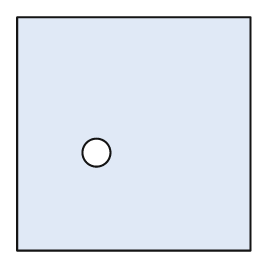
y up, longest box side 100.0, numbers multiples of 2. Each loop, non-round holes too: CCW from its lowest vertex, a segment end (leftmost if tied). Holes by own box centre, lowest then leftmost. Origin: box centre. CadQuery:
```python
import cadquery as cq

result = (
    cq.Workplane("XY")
    .moveTo(-50.0, -50.0)
    .lineTo(50.0, -50.0)
    .lineTo(50.0, 50.0)
    .lineTo(-50.0, 50.0)
    .close()
    .moveTo(-16.0, -8.0)
    .circle(6.0)
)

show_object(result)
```